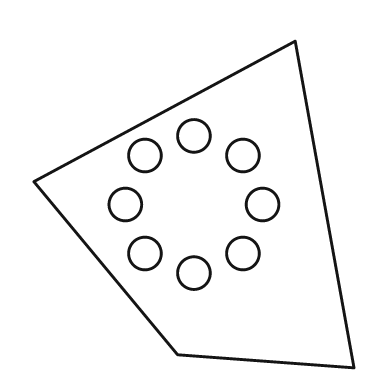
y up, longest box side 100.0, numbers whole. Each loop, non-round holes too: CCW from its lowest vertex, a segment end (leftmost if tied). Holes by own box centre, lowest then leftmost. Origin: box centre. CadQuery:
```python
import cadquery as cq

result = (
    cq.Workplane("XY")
    .moveTo(49.0, -50.0)
    .lineTo(31.0, 50.0)
    .lineTo(-49.0, 7.0)
    .lineTo(-5.0, -46.0)
    .close()
    .moveTo(0.0, -21.0)
    .circle(5.0)
    .moveTo(-15.0, -15.0)
    .circle(5.0)
    .moveTo(15.0, -15.0)
    .circle(5.0)
    .moveTo(-21.0, 0.0)
    .circle(5.0)
    .moveTo(21.0, 0.0)
    .circle(5.0)
    .moveTo(-15.0, 15.0)
    .circle(5.0)
    .moveTo(15.0, 15.0)
    .circle(5.0)
    .moveTo(0.0, 21.0)
    .circle(5.0)
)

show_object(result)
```